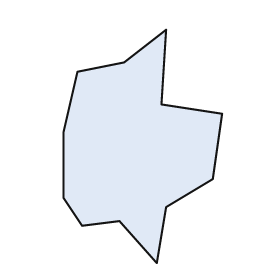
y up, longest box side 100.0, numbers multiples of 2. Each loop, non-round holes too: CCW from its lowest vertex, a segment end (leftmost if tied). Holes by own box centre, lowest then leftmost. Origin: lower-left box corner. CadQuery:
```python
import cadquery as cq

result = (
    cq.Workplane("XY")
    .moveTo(40.0, 0.0)
    .lineTo(44.0, 24.0)
    .lineTo(64.0, 36.0)
    .lineTo(68.0, 64.0)
    .lineTo(42.0, 68.0)
    .lineTo(44.0, 100.0)
    .lineTo(26.0, 86.0)
    .lineTo(6.0, 82.0)
    .lineTo(0.0, 56.0)
    .lineTo(0.0, 28.0)
    .lineTo(8.0, 16.0)
    .lineTo(24.0, 18.0)
    .close()
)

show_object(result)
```